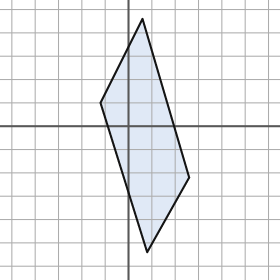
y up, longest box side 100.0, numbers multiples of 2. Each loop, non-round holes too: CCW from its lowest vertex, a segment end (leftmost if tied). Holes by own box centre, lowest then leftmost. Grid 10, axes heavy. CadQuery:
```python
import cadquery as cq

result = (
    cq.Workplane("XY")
    .moveTo(8.0, -54.0)
    .lineTo(26.0, -22.0)
    .lineTo(6.0, 46.0)
    .lineTo(-12.0, 10.0)
    .close()
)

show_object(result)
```